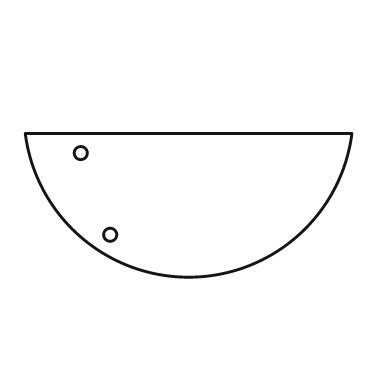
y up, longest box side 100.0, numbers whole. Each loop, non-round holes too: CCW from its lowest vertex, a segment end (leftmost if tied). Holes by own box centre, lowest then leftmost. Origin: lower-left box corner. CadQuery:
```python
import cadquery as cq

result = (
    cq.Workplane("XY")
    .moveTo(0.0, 44.0)
    .threePointArc((50.0, 0.0), (100.0, 44.0))
    .close()
    .moveTo(26.0, 13.0)
    .circle(2.0)
    .moveTo(17.0, 38.0)
    .circle(2.0)
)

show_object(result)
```